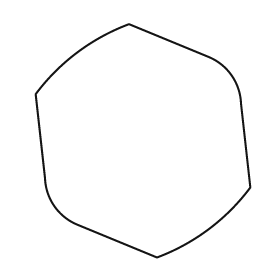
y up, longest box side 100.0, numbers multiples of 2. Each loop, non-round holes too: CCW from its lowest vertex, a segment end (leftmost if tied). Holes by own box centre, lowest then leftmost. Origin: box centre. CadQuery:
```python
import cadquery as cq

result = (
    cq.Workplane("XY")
    .moveTo(6.0, -50.0)
    .threePointArc((28.0, -38.0), (46.0, -20.0))
    .lineTo(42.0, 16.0)
    .threePointArc((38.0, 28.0), (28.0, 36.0))
    .lineTo(-6.0, 50.0)
    .threePointArc((-28.0, 38.0), (-46.0, 20.0))
    .lineTo(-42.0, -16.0)
    .threePointArc((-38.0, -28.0), (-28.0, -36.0))
    .close()
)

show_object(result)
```